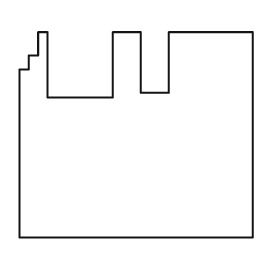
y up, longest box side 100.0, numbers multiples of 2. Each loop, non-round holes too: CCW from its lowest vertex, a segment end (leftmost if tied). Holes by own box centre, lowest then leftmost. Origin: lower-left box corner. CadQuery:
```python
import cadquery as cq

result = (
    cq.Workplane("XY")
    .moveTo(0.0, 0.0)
    .lineTo(100.0, 0.0)
    .lineTo(100.0, 88.0)
    .lineTo(64.0, 88.0)
    .lineTo(64.0, 62.0)
    .lineTo(52.0, 62.0)
    .lineTo(52.0, 88.0)
    .lineTo(40.0, 88.0)
    .lineTo(40.0, 60.0)
    .lineTo(12.0, 60.0)
    .lineTo(12.0, 88.0)
    .lineTo(8.0, 88.0)
    .lineTo(8.0, 78.0)
    .lineTo(4.0, 78.0)
    .lineTo(4.0, 72.0)
    .lineTo(0.0, 72.0)
    .close()
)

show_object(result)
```